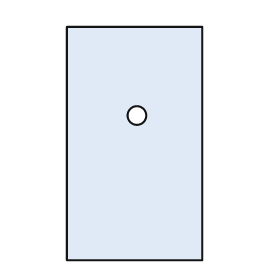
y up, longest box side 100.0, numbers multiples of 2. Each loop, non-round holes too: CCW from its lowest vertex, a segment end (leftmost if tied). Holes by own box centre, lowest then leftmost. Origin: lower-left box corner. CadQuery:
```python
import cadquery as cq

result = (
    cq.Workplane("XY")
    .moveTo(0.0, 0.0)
    .lineTo(58.0, 0.0)
    .lineTo(58.0, 100.0)
    .lineTo(0.0, 100.0)
    .close()
    .moveTo(30.0, 62.0)
    .circle(4.0)
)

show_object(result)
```